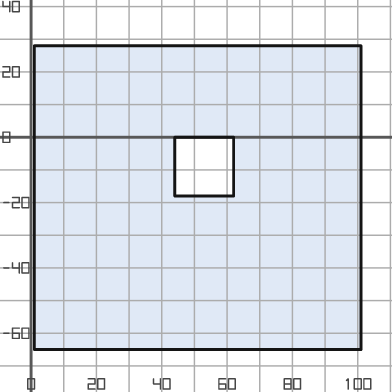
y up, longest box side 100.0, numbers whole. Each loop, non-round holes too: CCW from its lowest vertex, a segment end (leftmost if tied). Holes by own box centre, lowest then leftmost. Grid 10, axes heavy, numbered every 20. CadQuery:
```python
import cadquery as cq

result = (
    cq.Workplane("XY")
    .moveTo(1.0, -65.0)
    .lineTo(101.0, -65.0)
    .lineTo(101.0, 28.0)
    .lineTo(1.0, 28.0)
    .close()
    .moveTo(44.0, -18.0)
    .lineTo(62.0, -18.0)
    .lineTo(62.0, 0.0)
    .lineTo(44.0, 0.0)
    .close()
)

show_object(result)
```